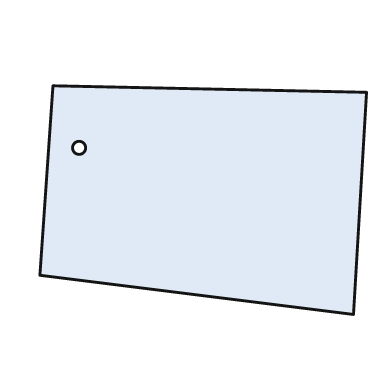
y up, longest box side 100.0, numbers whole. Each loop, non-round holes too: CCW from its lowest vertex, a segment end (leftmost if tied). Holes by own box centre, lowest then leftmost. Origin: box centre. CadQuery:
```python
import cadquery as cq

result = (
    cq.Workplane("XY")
    .moveTo(46.0, -35.0)
    .lineTo(50.0, 33.0)
    .lineTo(-46.0, 35.0)
    .lineTo(-50.0, -23.0)
    .close()
    .moveTo(-38.0, 16.0)
    .circle(2.0)
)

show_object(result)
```